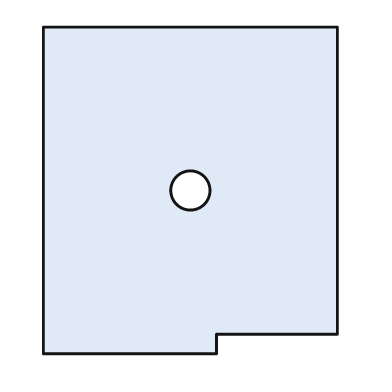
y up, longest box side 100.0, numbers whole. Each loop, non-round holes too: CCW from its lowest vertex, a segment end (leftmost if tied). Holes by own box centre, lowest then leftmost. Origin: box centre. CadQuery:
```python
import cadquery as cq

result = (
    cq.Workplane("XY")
    .moveTo(-45.0, -50.0)
    .lineTo(8.0, -50.0)
    .lineTo(8.0, -44.0)
    .lineTo(45.0, -44.0)
    .lineTo(45.0, 50.0)
    .lineTo(-45.0, 50.0)
    .close()
    .moveTo(0.0, 0.0)
    .circle(6.0)
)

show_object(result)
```